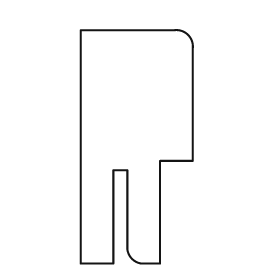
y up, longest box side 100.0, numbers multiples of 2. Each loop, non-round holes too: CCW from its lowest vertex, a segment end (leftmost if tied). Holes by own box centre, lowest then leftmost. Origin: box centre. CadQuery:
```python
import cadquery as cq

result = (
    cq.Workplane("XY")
    .moveTo(-24.0, -50.0)
    .lineTo(-10.0, -50.0)
    .lineTo(-10.0, -10.0)
    .lineTo(-4.0, -10.0)
    .lineTo(-4.0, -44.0)
    .threePointArc((-2.0, -48.0), (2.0, -50.0))
    .lineTo(10.0, -50.0)
    .lineTo(10.0, -6.0)
    .lineTo(24.0, -6.0)
    .lineTo(24.0, 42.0)
    .threePointArc((22.0, 48.0), (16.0, 50.0))
    .lineTo(-24.0, 50.0)
    .close()
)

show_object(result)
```